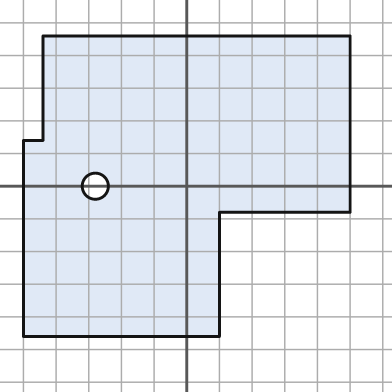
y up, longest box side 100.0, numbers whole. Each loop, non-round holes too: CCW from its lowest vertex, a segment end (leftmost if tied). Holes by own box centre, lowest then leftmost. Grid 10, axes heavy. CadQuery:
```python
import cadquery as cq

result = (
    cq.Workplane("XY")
    .moveTo(-50.0, -46.0)
    .lineTo(10.0, -46.0)
    .lineTo(10.0, -8.0)
    .lineTo(50.0, -8.0)
    .lineTo(50.0, 46.0)
    .lineTo(-44.0, 46.0)
    .lineTo(-44.0, 14.0)
    .lineTo(-50.0, 14.0)
    .close()
    .moveTo(-28.0, 0.0)
    .circle(4.0)
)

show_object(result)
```